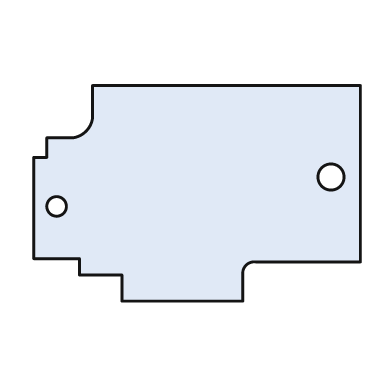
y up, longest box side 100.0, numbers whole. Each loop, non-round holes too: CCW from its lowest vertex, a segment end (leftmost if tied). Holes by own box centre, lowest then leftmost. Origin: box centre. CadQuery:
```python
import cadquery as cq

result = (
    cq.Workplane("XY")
    .moveTo(-23.0, -33.0)
    .lineTo(14.0, -33.0)
    .lineTo(14.0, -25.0)
    .threePointArc((15.0, -22.0), (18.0, -21.0))
    .lineTo(50.0, -21.0)
    .lineTo(50.0, 33.0)
    .lineTo(-32.0, 33.0)
    .lineTo(-32.0, 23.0)
    .threePointArc((-34.0, 19.0), (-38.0, 17.0))
    .lineTo(-46.0, 17.0)
    .lineTo(-46.0, 11.0)
    .lineTo(-50.0, 11.0)
    .lineTo(-50.0, -20.0)
    .lineTo(-36.0, -20.0)
    .lineTo(-36.0, -25.0)
    .lineTo(-23.0, -25.0)
    .close()
    .moveTo(-43.0, -4.0)
    .circle(3.0)
    .moveTo(41.0, 5.0)
    .circle(4.0)
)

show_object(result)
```